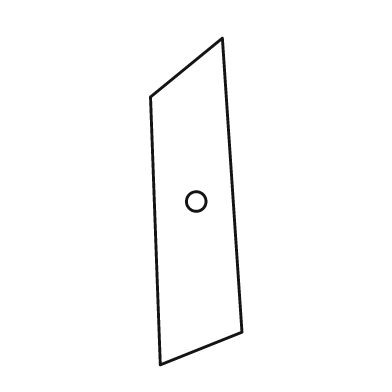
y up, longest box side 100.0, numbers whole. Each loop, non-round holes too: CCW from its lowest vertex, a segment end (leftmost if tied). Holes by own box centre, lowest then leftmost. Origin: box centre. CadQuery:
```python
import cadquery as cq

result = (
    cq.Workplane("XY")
    .moveTo(-11.0, -50.0)
    .lineTo(14.0, -40.0)
    .lineTo(8.0, 50.0)
    .lineTo(-14.0, 32.0)
    .close()
    .moveTo(0.0, 0.0)
    .circle(3.0)
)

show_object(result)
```